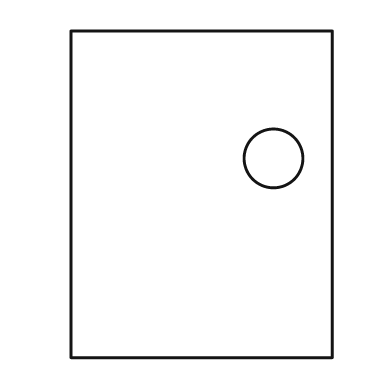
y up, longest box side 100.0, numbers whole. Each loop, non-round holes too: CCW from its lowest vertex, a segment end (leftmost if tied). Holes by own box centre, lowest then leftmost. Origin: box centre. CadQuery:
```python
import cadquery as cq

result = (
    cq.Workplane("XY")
    .moveTo(-40.0, -50.0)
    .lineTo(40.0, -50.0)
    .lineTo(40.0, 50.0)
    .lineTo(-40.0, 50.0)
    .close()
    .moveTo(22.0, 11.0)
    .circle(9.0)
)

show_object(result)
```